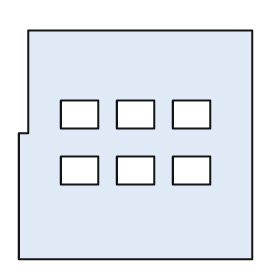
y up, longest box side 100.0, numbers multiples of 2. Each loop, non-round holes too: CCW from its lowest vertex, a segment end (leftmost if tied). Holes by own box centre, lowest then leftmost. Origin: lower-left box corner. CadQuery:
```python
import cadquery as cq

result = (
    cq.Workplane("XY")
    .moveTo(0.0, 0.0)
    .lineTo(100.0, 0.0)
    .lineTo(100.0, 98.0)
    .lineTo(4.0, 98.0)
    .lineTo(4.0, 54.0)
    .lineTo(0.0, 54.0)
    .close()
    .moveTo(18.0, 32.0)
    .lineTo(34.0, 32.0)
    .lineTo(34.0, 44.0)
    .lineTo(18.0, 44.0)
    .close()
    .moveTo(42.0, 32.0)
    .lineTo(58.0, 32.0)
    .lineTo(58.0, 44.0)
    .lineTo(42.0, 44.0)
    .close()
    .moveTo(66.0, 32.0)
    .lineTo(82.0, 32.0)
    .lineTo(82.0, 44.0)
    .lineTo(66.0, 44.0)
    .close()
    .moveTo(18.0, 56.0)
    .lineTo(34.0, 56.0)
    .lineTo(34.0, 68.0)
    .lineTo(18.0, 68.0)
    .close()
    .moveTo(42.0, 56.0)
    .lineTo(58.0, 56.0)
    .lineTo(58.0, 68.0)
    .lineTo(42.0, 68.0)
    .close()
    .moveTo(66.0, 56.0)
    .lineTo(82.0, 56.0)
    .lineTo(82.0, 68.0)
    .lineTo(66.0, 68.0)
    .close()
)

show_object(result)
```